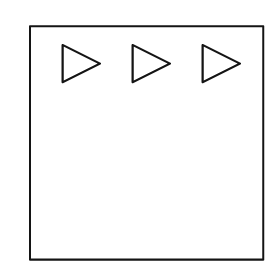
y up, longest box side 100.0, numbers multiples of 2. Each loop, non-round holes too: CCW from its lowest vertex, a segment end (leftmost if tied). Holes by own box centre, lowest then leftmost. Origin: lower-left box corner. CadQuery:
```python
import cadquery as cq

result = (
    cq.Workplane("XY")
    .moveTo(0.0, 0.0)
    .lineTo(100.0, 0.0)
    .lineTo(100.0, 100.0)
    .lineTo(0.0, 100.0)
    .close()
    .moveTo(14.0, 76.0)
    .lineTo(30.0, 84.0)
    .lineTo(14.0, 92.0)
    .close()
    .moveTo(44.0, 76.0)
    .lineTo(60.0, 84.0)
    .lineTo(44.0, 92.0)
    .close()
    .moveTo(74.0, 76.0)
    .lineTo(90.0, 84.0)
    .lineTo(74.0, 92.0)
    .close()
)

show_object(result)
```